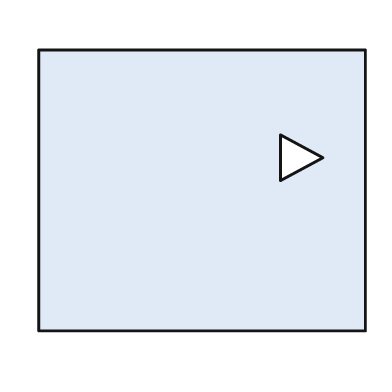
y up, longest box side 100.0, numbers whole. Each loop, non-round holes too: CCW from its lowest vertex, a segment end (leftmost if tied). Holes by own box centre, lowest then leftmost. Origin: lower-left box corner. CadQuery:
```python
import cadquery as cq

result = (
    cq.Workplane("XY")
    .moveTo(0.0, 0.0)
    .lineTo(100.0, 0.0)
    .lineTo(100.0, 86.0)
    .lineTo(0.0, 86.0)
    .close()
    .moveTo(74.0, 46.0)
    .lineTo(87.0, 53.0)
    .lineTo(74.0, 60.0)
    .close()
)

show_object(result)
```